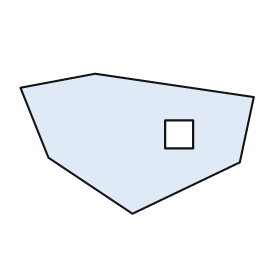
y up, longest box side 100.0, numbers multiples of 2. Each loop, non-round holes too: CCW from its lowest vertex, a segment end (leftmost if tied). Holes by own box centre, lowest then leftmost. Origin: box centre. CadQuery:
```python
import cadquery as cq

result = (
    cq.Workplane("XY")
    .moveTo(-2.0, -30.0)
    .lineTo(44.0, -8.0)
    .lineTo(50.0, 20.0)
    .lineTo(-18.0, 30.0)
    .lineTo(-50.0, 24.0)
    .lineTo(-38.0, -6.0)
    .close()
    .moveTo(12.0, -2.0)
    .lineTo(24.0, -2.0)
    .lineTo(24.0, 10.0)
    .lineTo(12.0, 10.0)
    .close()
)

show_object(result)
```